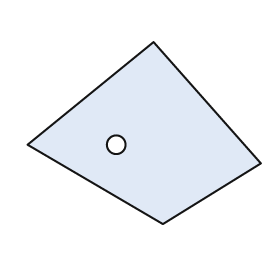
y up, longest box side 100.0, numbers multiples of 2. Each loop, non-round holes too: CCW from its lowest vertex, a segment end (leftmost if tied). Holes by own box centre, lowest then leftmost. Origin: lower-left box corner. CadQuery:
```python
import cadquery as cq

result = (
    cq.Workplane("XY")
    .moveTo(58.0, 0.0)
    .lineTo(100.0, 26.0)
    .lineTo(54.0, 78.0)
    .lineTo(0.0, 34.0)
    .close()
    .moveTo(38.0, 34.0)
    .circle(4.0)
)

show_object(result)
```